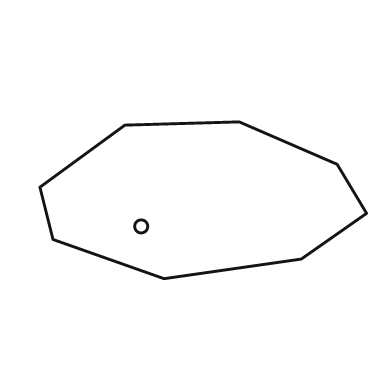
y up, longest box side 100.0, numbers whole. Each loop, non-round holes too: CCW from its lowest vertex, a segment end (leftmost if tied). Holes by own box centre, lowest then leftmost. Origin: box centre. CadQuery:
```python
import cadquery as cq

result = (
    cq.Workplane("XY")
    .moveTo(-12.0, -24.0)
    .lineTo(30.0, -18.0)
    .lineTo(50.0, -4.0)
    .lineTo(41.0, 11.0)
    .lineTo(11.0, 24.0)
    .lineTo(-24.0, 23.0)
    .lineTo(-50.0, 4.0)
    .lineTo(-46.0, -12.0)
    .close()
    .moveTo(-19.0, -8.0)
    .circle(2.0)
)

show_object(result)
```